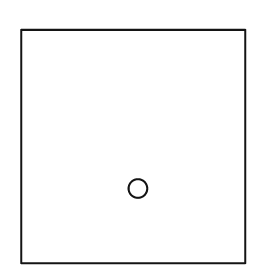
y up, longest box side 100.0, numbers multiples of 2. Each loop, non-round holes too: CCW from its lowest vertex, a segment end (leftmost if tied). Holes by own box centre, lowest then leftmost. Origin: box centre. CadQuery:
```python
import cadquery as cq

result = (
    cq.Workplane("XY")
    .moveTo(-48.0, -50.0)
    .lineTo(48.0, -50.0)
    .lineTo(48.0, 50.0)
    .lineTo(-48.0, 50.0)
    .close()
    .moveTo(2.0, -18.0)
    .circle(4.0)
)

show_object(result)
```